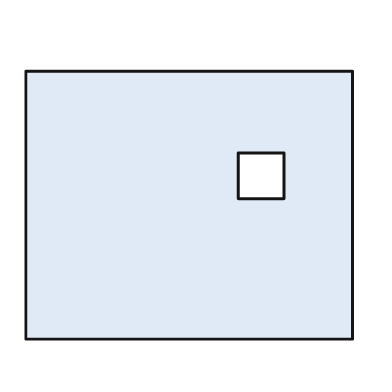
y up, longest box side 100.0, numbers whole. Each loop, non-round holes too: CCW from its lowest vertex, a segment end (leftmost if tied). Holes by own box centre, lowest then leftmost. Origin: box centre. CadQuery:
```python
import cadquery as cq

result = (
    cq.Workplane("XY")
    .moveTo(-50.0, -41.0)
    .lineTo(50.0, -41.0)
    .lineTo(50.0, 41.0)
    .lineTo(-50.0, 41.0)
    .close()
    .moveTo(15.0, 2.0)
    .lineTo(29.0, 2.0)
    .lineTo(29.0, 16.0)
    .lineTo(15.0, 16.0)
    .close()
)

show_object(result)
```